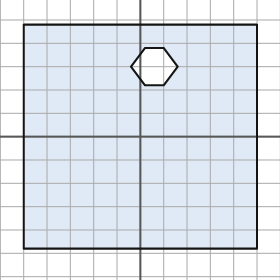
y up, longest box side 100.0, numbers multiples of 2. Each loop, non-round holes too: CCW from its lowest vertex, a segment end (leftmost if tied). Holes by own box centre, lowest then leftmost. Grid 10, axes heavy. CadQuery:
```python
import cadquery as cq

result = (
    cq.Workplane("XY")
    .moveTo(-50.0, -48.0)
    .lineTo(50.0, -48.0)
    .lineTo(50.0, 48.0)
    .lineTo(-50.0, 48.0)
    .close()
    .moveTo(2.0, 22.0)
    .lineTo(10.0, 22.0)
    .lineTo(16.0, 30.0)
    .lineTo(10.0, 38.0)
    .lineTo(2.0, 38.0)
    .lineTo(-4.0, 30.0)
    .close()
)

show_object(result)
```